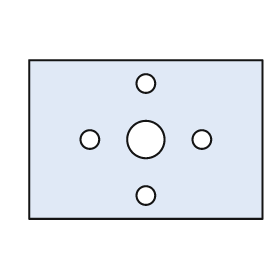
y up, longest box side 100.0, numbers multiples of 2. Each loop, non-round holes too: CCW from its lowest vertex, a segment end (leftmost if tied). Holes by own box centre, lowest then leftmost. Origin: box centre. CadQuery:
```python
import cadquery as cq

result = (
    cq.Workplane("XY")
    .moveTo(-50.0, -34.0)
    .lineTo(50.0, -34.0)
    .lineTo(50.0, 34.0)
    .lineTo(-50.0, 34.0)
    .close()
    .moveTo(0.0, -24.0)
    .circle(4.0)
    .moveTo(-24.0, 0.0)
    .circle(4.0)
    .moveTo(0.0, 0.0)
    .circle(8.0)
    .moveTo(24.0, 0.0)
    .circle(4.0)
    .moveTo(0.0, 24.0)
    .circle(4.0)
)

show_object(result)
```